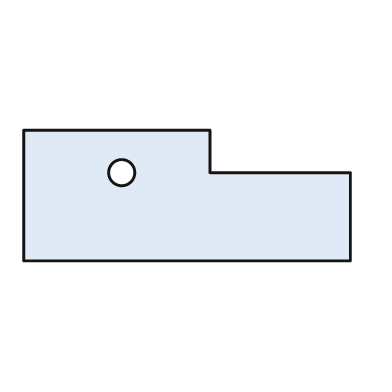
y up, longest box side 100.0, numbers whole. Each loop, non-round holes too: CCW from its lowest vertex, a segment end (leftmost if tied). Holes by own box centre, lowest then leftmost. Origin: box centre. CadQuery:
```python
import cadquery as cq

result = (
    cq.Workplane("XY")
    .moveTo(-50.0, -20.0)
    .lineTo(50.0, -20.0)
    .lineTo(50.0, 7.0)
    .lineTo(7.0, 7.0)
    .lineTo(7.0, 20.0)
    .lineTo(-50.0, 20.0)
    .close()
    .moveTo(-20.0, 7.0)
    .circle(4.0)
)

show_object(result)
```